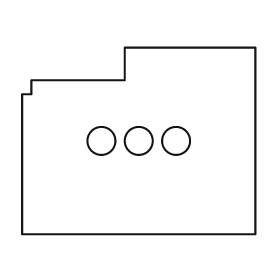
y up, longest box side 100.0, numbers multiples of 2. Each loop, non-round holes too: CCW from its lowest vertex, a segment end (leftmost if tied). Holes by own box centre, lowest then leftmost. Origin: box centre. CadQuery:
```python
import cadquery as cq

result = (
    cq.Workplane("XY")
    .moveTo(-50.0, -40.0)
    .lineTo(50.0, -40.0)
    .lineTo(50.0, 40.0)
    .lineTo(-6.0, 40.0)
    .lineTo(-6.0, 26.0)
    .lineTo(-46.0, 26.0)
    .lineTo(-46.0, 20.0)
    .lineTo(-50.0, 20.0)
    .close()
    .moveTo(-16.0, 0.0)
    .circle(6.0)
    .moveTo(0.0, 0.0)
    .circle(6.0)
    .moveTo(16.0, 0.0)
    .circle(6.0)
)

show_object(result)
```